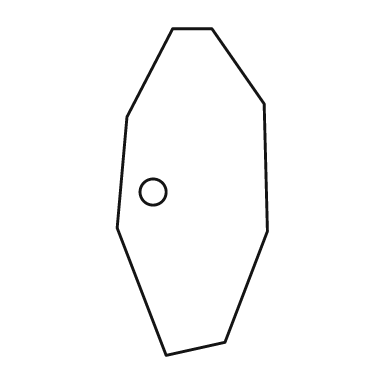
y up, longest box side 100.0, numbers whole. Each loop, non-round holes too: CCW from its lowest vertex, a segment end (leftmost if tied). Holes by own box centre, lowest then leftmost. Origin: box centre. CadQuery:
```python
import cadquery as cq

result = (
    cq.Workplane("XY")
    .moveTo(-8.0, -50.0)
    .lineTo(10.0, -46.0)
    .lineTo(23.0, -12.0)
    .lineTo(22.0, 27.0)
    .lineTo(6.0, 50.0)
    .lineTo(-6.0, 50.0)
    .lineTo(-20.0, 23.0)
    .lineTo(-23.0, -11.0)
    .close()
    .moveTo(-12.0, 0.0)
    .circle(4.0)
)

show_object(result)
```